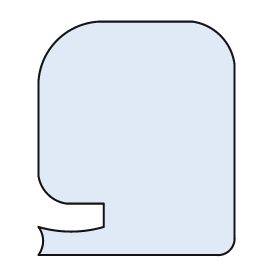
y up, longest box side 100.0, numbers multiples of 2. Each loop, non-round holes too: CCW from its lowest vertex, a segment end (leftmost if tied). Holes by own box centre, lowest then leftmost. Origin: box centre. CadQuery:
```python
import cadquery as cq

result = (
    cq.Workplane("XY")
    .moveTo(-42.0, -50.0)
    .lineTo(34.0, -50.0)
    .threePointArc((40.0, -48.0), (42.0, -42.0))
    .lineTo(42.0, 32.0)
    .threePointArc((36.0, 44.0), (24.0, 50.0))
    .lineTo(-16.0, 50.0)
    .threePointArc((-34.0, 42.0), (-42.0, 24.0))
    .lineTo(-42.0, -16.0)
    .threePointArc((-38.0, -24.0), (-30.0, -28.0))
    .lineTo(-14.0, -28.0)
    .lineTo(-14.0, -38.0)
    .threePointArc((-28.0, -40.0), (-42.0, -38.0))
    .threePointArc((-40.0, -44.0), (-42.0, -50.0))
    .close()
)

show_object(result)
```